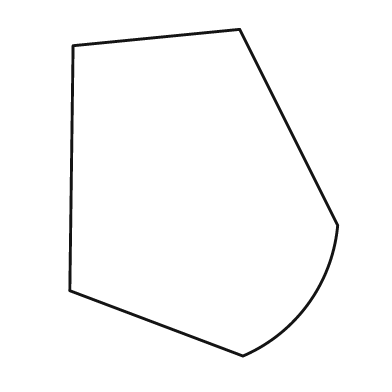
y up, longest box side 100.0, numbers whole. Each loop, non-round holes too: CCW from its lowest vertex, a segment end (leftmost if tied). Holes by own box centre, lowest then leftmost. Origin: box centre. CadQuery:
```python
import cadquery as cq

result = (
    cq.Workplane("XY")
    .moveTo(12.0, -50.0)
    .threePointArc((32.0, -34.0), (41.0, -10.0))
    .lineTo(11.0, 50.0)
    .lineTo(-40.0, 45.0)
    .lineTo(-41.0, -30.0)
    .close()
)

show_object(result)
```